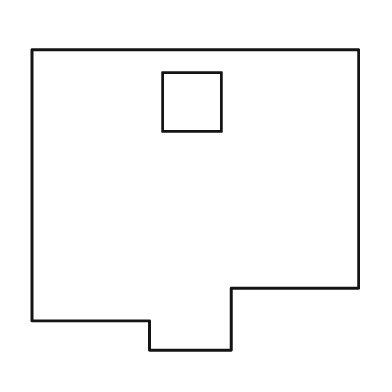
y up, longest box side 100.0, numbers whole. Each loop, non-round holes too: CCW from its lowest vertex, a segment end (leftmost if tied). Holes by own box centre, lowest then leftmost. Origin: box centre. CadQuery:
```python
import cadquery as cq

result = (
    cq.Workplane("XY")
    .moveTo(-14.0, -46.0)
    .lineTo(11.0, -46.0)
    .lineTo(11.0, -27.0)
    .lineTo(50.0, -27.0)
    .lineTo(50.0, 46.0)
    .lineTo(-50.0, 46.0)
    .lineTo(-50.0, -37.0)
    .lineTo(-14.0, -37.0)
    .close()
    .moveTo(-10.0, 21.0)
    .lineTo(8.0, 21.0)
    .lineTo(8.0, 39.0)
    .lineTo(-10.0, 39.0)
    .close()
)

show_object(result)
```